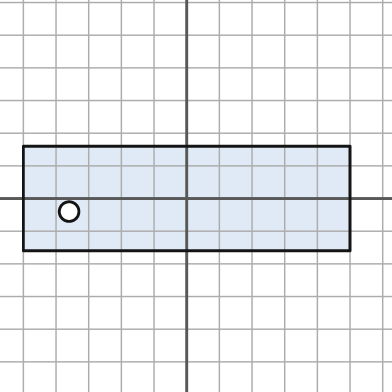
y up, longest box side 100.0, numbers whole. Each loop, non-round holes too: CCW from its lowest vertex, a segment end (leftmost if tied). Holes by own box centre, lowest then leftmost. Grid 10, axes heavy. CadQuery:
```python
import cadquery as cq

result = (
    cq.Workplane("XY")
    .moveTo(-50.0, -16.0)
    .lineTo(50.0, -16.0)
    .lineTo(50.0, 16.0)
    .lineTo(-50.0, 16.0)
    .close()
    .moveTo(-36.0, -4.0)
    .circle(3.0)
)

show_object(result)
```